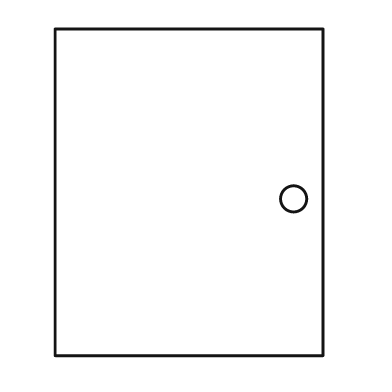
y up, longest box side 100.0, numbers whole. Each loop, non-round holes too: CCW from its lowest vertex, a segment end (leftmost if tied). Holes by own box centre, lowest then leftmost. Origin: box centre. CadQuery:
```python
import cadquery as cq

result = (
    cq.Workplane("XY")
    .moveTo(-41.0, -50.0)
    .lineTo(41.0, -50.0)
    .lineTo(41.0, 50.0)
    .lineTo(-41.0, 50.0)
    .close()
    .moveTo(32.0, -2.0)
    .circle(4.0)
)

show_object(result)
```